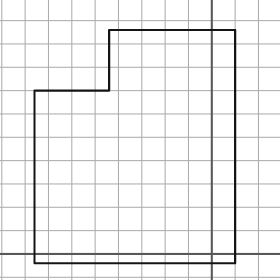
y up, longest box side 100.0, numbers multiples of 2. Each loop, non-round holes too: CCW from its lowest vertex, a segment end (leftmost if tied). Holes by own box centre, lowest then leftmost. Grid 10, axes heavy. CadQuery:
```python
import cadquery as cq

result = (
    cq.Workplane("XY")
    .moveTo(-76.0, -4.0)
    .lineTo(10.0, -4.0)
    .lineTo(10.0, 96.0)
    .lineTo(-44.0, 96.0)
    .lineTo(-44.0, 70.0)
    .lineTo(-76.0, 70.0)
    .close()
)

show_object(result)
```